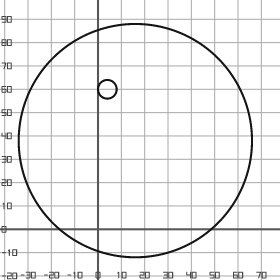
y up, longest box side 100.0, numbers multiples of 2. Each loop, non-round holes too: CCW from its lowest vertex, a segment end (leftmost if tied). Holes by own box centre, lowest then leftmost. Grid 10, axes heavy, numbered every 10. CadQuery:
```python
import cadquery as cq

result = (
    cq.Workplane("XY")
    .moveTo(16.0, 38.0)
    .circle(50.0)
    .moveTo(4.0, 60.0)
    .circle(4.0)
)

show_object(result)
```